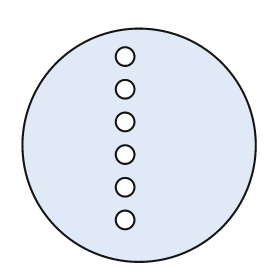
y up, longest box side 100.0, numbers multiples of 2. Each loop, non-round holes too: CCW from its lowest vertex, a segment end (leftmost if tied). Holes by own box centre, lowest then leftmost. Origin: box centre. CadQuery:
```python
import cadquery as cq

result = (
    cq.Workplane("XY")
    .moveTo(0.0, 0.0)
    .circle(50.0)
    .moveTo(-6.0, -32.0)
    .circle(4.0)
    .moveTo(-6.0, -18.0)
    .circle(4.0)
    .moveTo(-6.0, -4.0)
    .circle(4.0)
    .moveTo(-6.0, 10.0)
    .circle(4.0)
    .moveTo(-6.0, 24.0)
    .circle(4.0)
    .moveTo(-6.0, 38.0)
    .circle(4.0)
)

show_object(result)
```